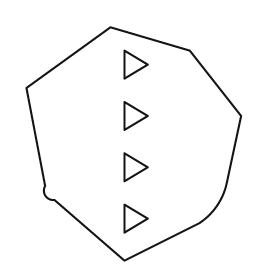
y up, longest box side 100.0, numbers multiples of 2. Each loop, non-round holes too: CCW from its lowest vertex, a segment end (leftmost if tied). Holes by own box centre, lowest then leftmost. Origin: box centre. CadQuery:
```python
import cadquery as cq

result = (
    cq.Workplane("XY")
    .moveTo(-4.0, -50.0)
    .lineTo(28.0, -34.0)
    .threePointArc((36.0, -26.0), (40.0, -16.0))
    .lineTo(46.0, 12.0)
    .lineTo(24.0, 40.0)
    .lineTo(-10.0, 50.0)
    .lineTo(-46.0, 24.0)
    .lineTo(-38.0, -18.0)
    .threePointArc((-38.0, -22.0), (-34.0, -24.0))
    .close()
    .moveTo(-4.0, -38.0)
    .lineTo(6.0, -32.0)
    .lineTo(-4.0, -26.0)
    .close()
    .moveTo(-4.0, -16.0)
    .lineTo(6.0, -10.0)
    .lineTo(-4.0, -4.0)
    .close()
    .moveTo(-4.0, 6.0)
    .lineTo(6.0, 12.0)
    .lineTo(-4.0, 18.0)
    .close()
    .moveTo(-4.0, 28.0)
    .lineTo(6.0, 34.0)
    .lineTo(-4.0, 40.0)
    .close()
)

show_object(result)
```